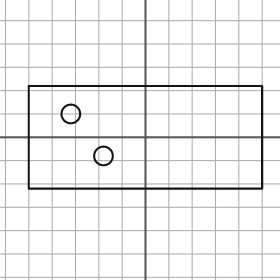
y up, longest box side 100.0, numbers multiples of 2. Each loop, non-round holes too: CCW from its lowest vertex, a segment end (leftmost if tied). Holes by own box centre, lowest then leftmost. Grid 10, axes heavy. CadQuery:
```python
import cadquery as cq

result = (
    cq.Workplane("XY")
    .moveTo(-50.0, -22.0)
    .lineTo(50.0, -22.0)
    .lineTo(50.0, 22.0)
    .lineTo(-50.0, 22.0)
    .close()
    .moveTo(-18.0, -8.0)
    .circle(4.0)
    .moveTo(-32.0, 10.0)
    .circle(4.0)
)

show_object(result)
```